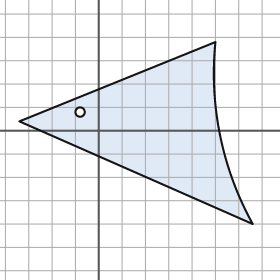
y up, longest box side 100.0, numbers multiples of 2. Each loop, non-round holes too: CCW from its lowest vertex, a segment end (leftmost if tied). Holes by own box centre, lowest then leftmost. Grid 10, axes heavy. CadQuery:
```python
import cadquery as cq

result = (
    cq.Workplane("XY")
    .moveTo(66.0, -40.0)
    .threePointArc((52.0, -2.0), (50.0, 38.0))
    .lineTo(-34.0, 4.0)
    .close()
    .moveTo(-8.0, 8.0)
    .circle(2.0)
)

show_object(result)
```